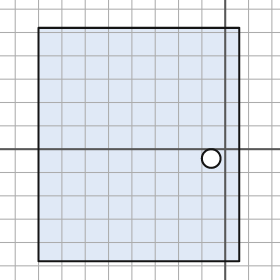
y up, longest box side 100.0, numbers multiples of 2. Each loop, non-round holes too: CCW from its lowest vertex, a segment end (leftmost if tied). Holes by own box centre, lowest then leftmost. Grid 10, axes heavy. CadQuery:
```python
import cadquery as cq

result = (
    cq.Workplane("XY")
    .moveTo(-80.0, -48.0)
    .lineTo(6.0, -48.0)
    .lineTo(6.0, 52.0)
    .lineTo(-80.0, 52.0)
    .close()
    .moveTo(-6.0, -4.0)
    .circle(4.0)
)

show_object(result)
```